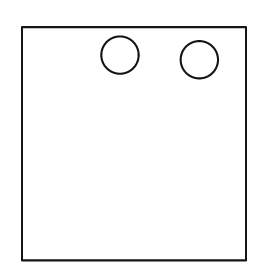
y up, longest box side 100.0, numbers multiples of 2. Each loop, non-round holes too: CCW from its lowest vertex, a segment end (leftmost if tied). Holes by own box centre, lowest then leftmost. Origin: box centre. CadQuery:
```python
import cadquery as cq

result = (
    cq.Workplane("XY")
    .moveTo(-48.0, -50.0)
    .lineTo(48.0, -50.0)
    .lineTo(48.0, 50.0)
    .lineTo(-48.0, 50.0)
    .close()
    .moveTo(28.0, 36.0)
    .circle(8.0)
    .moveTo(-6.0, 38.0)
    .circle(8.0)
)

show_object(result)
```